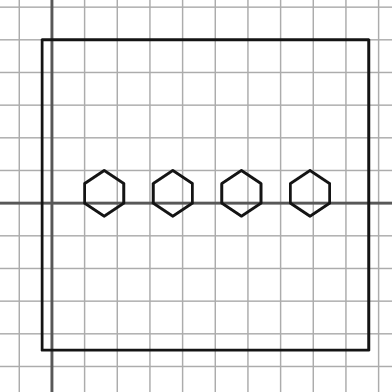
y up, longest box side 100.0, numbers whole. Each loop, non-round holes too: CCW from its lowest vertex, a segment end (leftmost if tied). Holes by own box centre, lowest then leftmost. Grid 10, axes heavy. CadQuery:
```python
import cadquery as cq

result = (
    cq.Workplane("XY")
    .moveTo(-3.0, -45.0)
    .lineTo(97.0, -45.0)
    .lineTo(97.0, 50.0)
    .lineTo(-3.0, 50.0)
    .close()
    .moveTo(16.0, -4.0)
    .lineTo(22.0, 0.0)
    .lineTo(22.0, 6.0)
    .lineTo(16.0, 10.0)
    .lineTo(10.0, 6.0)
    .lineTo(10.0, 0.0)
    .close()
    .moveTo(37.0, -4.0)
    .lineTo(43.0, 0.0)
    .lineTo(43.0, 6.0)
    .lineTo(37.0, 10.0)
    .lineTo(31.0, 6.0)
    .lineTo(31.0, 0.0)
    .close()
    .moveTo(58.0, -4.0)
    .lineTo(64.0, 0.0)
    .lineTo(64.0, 6.0)
    .lineTo(58.0, 10.0)
    .lineTo(52.0, 6.0)
    .lineTo(52.0, 0.0)
    .close()
    .moveTo(79.0, -4.0)
    .lineTo(85.0, 0.0)
    .lineTo(85.0, 6.0)
    .lineTo(79.0, 10.0)
    .lineTo(73.0, 6.0)
    .lineTo(73.0, 0.0)
    .close()
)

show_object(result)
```